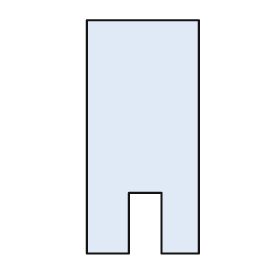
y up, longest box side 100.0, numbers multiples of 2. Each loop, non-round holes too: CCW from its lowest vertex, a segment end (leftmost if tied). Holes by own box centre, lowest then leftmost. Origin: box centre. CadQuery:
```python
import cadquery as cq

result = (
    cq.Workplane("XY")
    .moveTo(-24.0, -50.0)
    .lineTo(-6.0, -50.0)
    .lineTo(-6.0, -24.0)
    .lineTo(8.0, -24.0)
    .lineTo(8.0, -50.0)
    .lineTo(24.0, -50.0)
    .lineTo(24.0, 50.0)
    .lineTo(-24.0, 50.0)
    .close()
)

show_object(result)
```